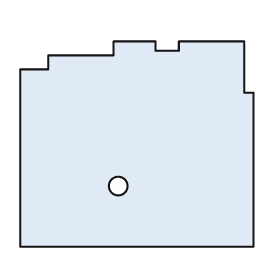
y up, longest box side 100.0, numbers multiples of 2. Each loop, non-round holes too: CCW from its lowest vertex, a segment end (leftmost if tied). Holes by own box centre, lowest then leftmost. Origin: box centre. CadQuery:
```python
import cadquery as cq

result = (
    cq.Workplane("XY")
    .moveTo(-50.0, -44.0)
    .lineTo(50.0, -44.0)
    .lineTo(50.0, 22.0)
    .lineTo(46.0, 22.0)
    .lineTo(46.0, 44.0)
    .lineTo(18.0, 44.0)
    .lineTo(18.0, 40.0)
    .lineTo(8.0, 40.0)
    .lineTo(8.0, 44.0)
    .lineTo(-10.0, 44.0)
    .lineTo(-10.0, 38.0)
    .lineTo(-38.0, 38.0)
    .lineTo(-38.0, 32.0)
    .lineTo(-50.0, 32.0)
    .close()
    .moveTo(-8.0, -18.0)
    .circle(4.0)
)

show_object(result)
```